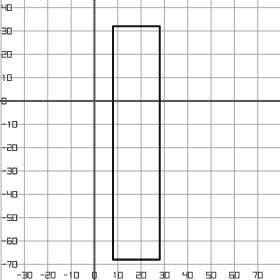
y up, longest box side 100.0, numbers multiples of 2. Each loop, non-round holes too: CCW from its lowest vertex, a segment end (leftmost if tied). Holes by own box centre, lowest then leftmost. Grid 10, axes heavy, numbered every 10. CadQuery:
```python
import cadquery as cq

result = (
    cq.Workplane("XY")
    .moveTo(8.0, -68.0)
    .lineTo(28.0, -68.0)
    .lineTo(28.0, 32.0)
    .lineTo(8.0, 32.0)
    .close()
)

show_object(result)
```